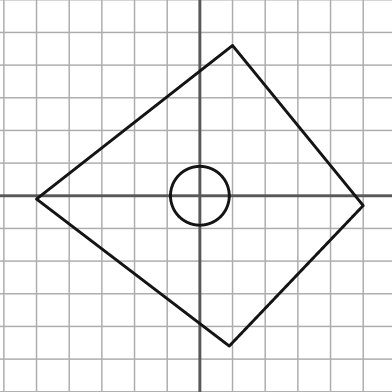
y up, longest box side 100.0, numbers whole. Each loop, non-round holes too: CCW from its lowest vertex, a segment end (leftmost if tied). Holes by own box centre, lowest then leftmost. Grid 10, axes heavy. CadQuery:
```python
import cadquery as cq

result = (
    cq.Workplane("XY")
    .moveTo(9.0, -46.0)
    .lineTo(50.0, -3.0)
    .lineTo(10.0, 46.0)
    .lineTo(-50.0, -1.0)
    .close()
    .moveTo(0.0, 0.0)
    .circle(9.0)
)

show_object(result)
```